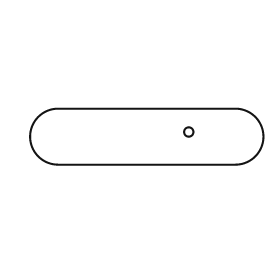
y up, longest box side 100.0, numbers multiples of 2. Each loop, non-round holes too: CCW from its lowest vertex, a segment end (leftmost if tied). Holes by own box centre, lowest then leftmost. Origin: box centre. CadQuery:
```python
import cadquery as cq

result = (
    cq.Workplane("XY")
    .moveTo(-38.0, -12.0)
    .lineTo(38.0, -12.0)
    .threePointArc((50.0, 0.0), (38.0, 12.0))
    .lineTo(-38.0, 12.0)
    .threePointArc((-50.0, 0.0), (-38.0, -12.0))
    .close()
    .moveTo(18.0, 2.0)
    .circle(2.0)
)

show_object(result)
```